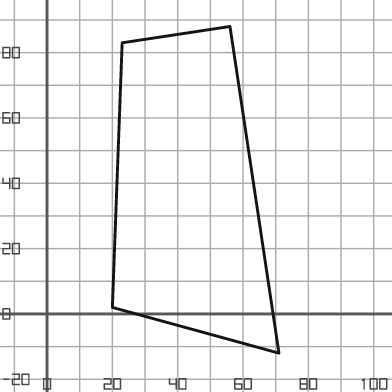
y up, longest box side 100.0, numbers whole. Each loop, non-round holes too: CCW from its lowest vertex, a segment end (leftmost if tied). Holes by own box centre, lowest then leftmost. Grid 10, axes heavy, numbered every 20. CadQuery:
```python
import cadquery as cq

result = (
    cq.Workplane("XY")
    .moveTo(71.0, -12.0)
    .lineTo(56.0, 88.0)
    .lineTo(23.0, 83.0)
    .lineTo(20.0, 2.0)
    .close()
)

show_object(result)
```